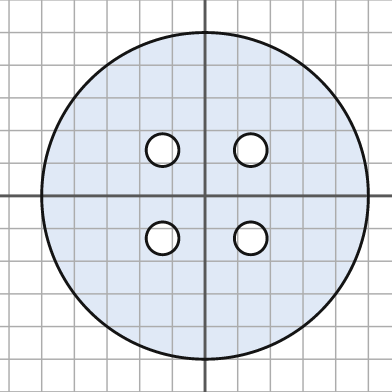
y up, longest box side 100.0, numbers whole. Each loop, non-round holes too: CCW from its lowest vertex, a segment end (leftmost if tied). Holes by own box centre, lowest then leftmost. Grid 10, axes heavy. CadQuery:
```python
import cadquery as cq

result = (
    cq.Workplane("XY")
    .moveTo(0.0, 0.0)
    .circle(50.0)
    .moveTo(-13.0, -13.0)
    .circle(5.0)
    .moveTo(14.0, -13.0)
    .circle(5.0)
    .moveTo(-13.0, 14.0)
    .circle(5.0)
    .moveTo(14.0, 14.0)
    .circle(5.0)
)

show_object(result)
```